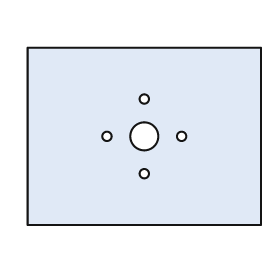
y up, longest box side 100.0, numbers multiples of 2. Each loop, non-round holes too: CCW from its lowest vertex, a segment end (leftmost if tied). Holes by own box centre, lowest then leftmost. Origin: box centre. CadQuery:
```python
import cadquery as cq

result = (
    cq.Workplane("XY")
    .moveTo(-50.0, -38.0)
    .lineTo(50.0, -38.0)
    .lineTo(50.0, 38.0)
    .lineTo(-50.0, 38.0)
    .close()
    .moveTo(0.0, -16.0)
    .circle(2.0)
    .moveTo(-16.0, 0.0)
    .circle(2.0)
    .moveTo(0.0, 0.0)
    .circle(6.0)
    .moveTo(16.0, 0.0)
    .circle(2.0)
    .moveTo(0.0, 16.0)
    .circle(2.0)
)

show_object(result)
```